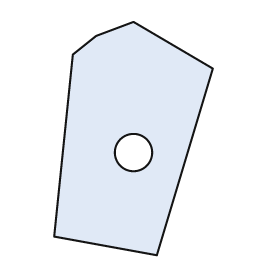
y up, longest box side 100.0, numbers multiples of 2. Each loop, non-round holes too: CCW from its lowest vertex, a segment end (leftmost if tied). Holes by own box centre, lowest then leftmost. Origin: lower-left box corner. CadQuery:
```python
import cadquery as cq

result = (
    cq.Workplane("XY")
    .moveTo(44.0, 0.0)
    .lineTo(68.0, 80.0)
    .lineTo(34.0, 100.0)
    .lineTo(18.0, 94.0)
    .lineTo(8.0, 86.0)
    .lineTo(0.0, 8.0)
    .close()
    .moveTo(34.0, 44.0)
    .circle(8.0)
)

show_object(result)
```